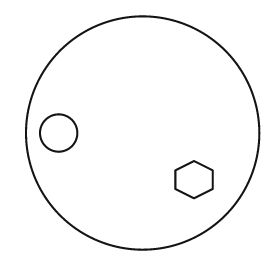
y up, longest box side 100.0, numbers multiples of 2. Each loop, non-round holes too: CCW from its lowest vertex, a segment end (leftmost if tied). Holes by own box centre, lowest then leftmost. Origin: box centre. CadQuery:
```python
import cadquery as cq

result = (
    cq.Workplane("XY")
    .moveTo(0.0, 0.0)
    .circle(50.0)
    .moveTo(22.0, -28.0)
    .lineTo(30.0, -24.0)
    .lineTo(30.0, -16.0)
    .lineTo(22.0, -12.0)
    .lineTo(14.0, -16.0)
    .lineTo(14.0, -24.0)
    .close()
    .moveTo(-36.0, 0.0)
    .circle(8.0)
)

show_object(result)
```